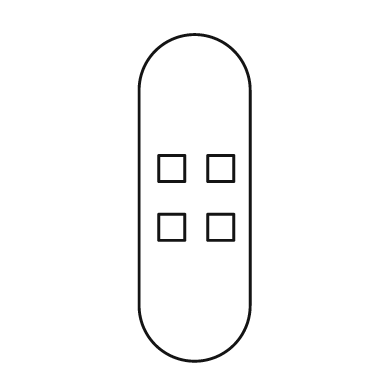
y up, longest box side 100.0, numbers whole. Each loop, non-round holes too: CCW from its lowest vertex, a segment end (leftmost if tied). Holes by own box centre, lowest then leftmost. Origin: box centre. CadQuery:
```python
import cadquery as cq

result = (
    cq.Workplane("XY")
    .moveTo(-17.0, -33.0)
    .threePointArc((0.0, -50.0), (17.0, -33.0))
    .lineTo(17.0, 33.0)
    .threePointArc((0.0, 50.0), (-17.0, 33.0))
    .close()
    .moveTo(-11.0, -13.0)
    .lineTo(-3.0, -13.0)
    .lineTo(-3.0, -5.0)
    .lineTo(-11.0, -5.0)
    .close()
    .moveTo(4.0, -13.0)
    .lineTo(12.0, -13.0)
    .lineTo(12.0, -5.0)
    .lineTo(4.0, -5.0)
    .close()
    .moveTo(-11.0, 5.0)
    .lineTo(-3.0, 5.0)
    .lineTo(-3.0, 13.0)
    .lineTo(-11.0, 13.0)
    .close()
    .moveTo(4.0, 5.0)
    .lineTo(12.0, 5.0)
    .lineTo(12.0, 13.0)
    .lineTo(4.0, 13.0)
    .close()
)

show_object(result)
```